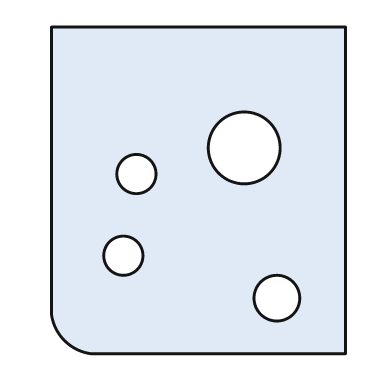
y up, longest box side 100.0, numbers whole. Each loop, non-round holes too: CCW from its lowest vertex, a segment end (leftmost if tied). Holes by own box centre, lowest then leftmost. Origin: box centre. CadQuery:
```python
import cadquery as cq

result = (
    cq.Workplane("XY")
    .moveTo(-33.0, -50.0)
    .lineTo(45.0, -50.0)
    .lineTo(45.0, 50.0)
    .lineTo(-45.0, 50.0)
    .lineTo(-45.0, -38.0)
    .threePointArc((-41.0, -46.0), (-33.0, -50.0))
    .close()
    .moveTo(24.0, -33.0)
    .circle(7.0)
    .moveTo(-23.0, -20.0)
    .circle(6.0)
    .moveTo(-19.0, 5.0)
    .circle(6.0)
    .moveTo(14.0, 13.0)
    .circle(11.0)
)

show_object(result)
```